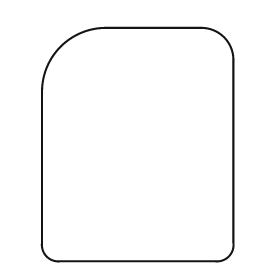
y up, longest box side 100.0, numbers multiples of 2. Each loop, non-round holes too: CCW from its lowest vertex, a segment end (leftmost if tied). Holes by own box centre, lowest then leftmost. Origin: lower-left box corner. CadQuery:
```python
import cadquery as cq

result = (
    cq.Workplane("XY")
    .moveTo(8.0, 0.0)
    .lineTo(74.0, 0.0)
    .threePointArc((80.0, 2.0), (82.0, 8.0))
    .lineTo(82.0, 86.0)
    .threePointArc((78.0, 96.0), (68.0, 100.0))
    .lineTo(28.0, 100.0)
    .threePointArc((8.0, 92.0), (0.0, 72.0))
    .lineTo(0.0, 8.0)
    .threePointArc((2.0, 2.0), (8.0, 0.0))
    .close()
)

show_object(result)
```